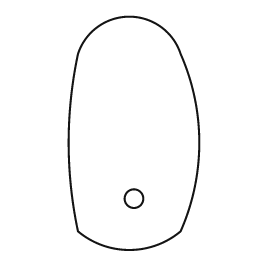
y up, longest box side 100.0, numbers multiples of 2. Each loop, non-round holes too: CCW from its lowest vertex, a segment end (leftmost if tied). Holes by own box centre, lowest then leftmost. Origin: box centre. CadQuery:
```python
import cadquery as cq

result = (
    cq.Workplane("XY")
    .moveTo(-24.0, -42.0)
    .threePointArc((-2.0, -50.0), (20.0, -42.0))
    .threePointArc((28.0, -4.0), (20.0, 34.0))
    .threePointArc((-2.0, 50.0), (-24.0, 34.0))
    .threePointArc((-28.0, -4.0), (-24.0, -42.0))
    .close()
    .moveTo(0.0, -28.0)
    .circle(4.0)
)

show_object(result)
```